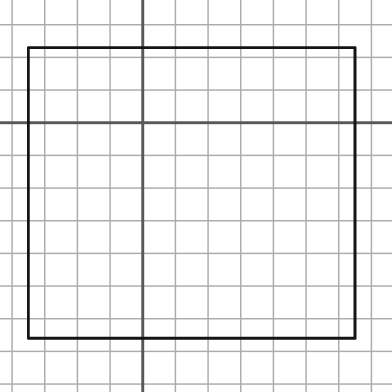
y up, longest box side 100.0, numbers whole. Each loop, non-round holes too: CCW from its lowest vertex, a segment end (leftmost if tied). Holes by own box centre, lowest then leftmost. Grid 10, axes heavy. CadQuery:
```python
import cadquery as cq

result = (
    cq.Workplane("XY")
    .moveTo(-35.0, -66.0)
    .lineTo(65.0, -66.0)
    .lineTo(65.0, 23.0)
    .lineTo(-35.0, 23.0)
    .close()
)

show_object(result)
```